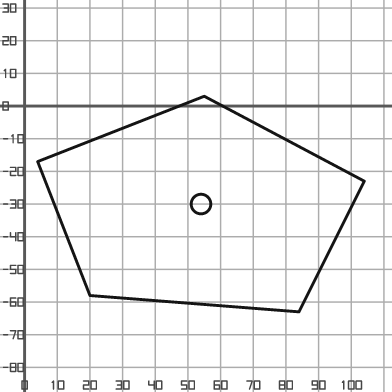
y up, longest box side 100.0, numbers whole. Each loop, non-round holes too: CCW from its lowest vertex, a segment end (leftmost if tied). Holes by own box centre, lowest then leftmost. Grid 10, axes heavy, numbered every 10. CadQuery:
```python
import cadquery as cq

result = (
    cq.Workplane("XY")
    .moveTo(84.0, -63.0)
    .lineTo(104.0, -23.0)
    .lineTo(55.0, 3.0)
    .lineTo(4.0, -17.0)
    .lineTo(20.0, -58.0)
    .close()
    .moveTo(54.0, -30.0)
    .circle(3.0)
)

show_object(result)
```